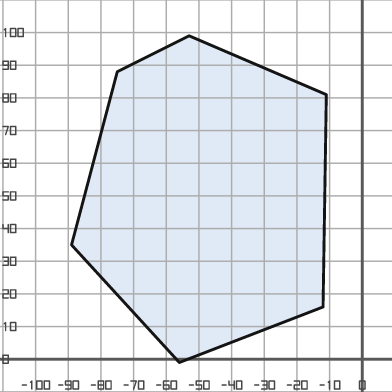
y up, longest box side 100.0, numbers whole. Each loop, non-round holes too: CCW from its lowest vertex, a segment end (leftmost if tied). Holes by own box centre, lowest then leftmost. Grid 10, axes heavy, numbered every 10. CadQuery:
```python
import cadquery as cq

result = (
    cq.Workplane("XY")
    .moveTo(-56.0, -1.0)
    .lineTo(-12.0, 16.0)
    .lineTo(-11.0, 81.0)
    .lineTo(-53.0, 99.0)
    .lineTo(-75.0, 88.0)
    .lineTo(-89.0, 35.0)
    .close()
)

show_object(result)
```